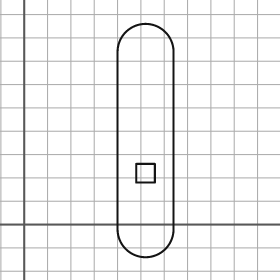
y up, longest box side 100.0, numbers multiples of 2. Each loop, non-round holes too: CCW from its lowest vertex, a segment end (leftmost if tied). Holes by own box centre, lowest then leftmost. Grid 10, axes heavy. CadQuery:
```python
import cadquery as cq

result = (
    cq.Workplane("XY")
    .moveTo(40.0, -2.0)
    .threePointArc((52.0, -14.0), (64.0, -2.0))
    .lineTo(64.0, 74.0)
    .threePointArc((52.0, 86.0), (40.0, 74.0))
    .close()
    .moveTo(48.0, 18.0)
    .lineTo(56.0, 18.0)
    .lineTo(56.0, 26.0)
    .lineTo(48.0, 26.0)
    .close()
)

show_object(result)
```